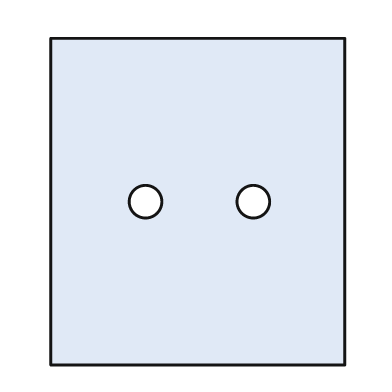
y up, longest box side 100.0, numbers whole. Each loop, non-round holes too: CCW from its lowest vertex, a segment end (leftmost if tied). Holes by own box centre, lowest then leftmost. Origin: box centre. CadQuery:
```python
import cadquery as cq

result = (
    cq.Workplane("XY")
    .moveTo(-45.0, -50.0)
    .lineTo(45.0, -50.0)
    .lineTo(45.0, 50.0)
    .lineTo(-45.0, 50.0)
    .close()
    .moveTo(-16.0, 0.0)
    .circle(5.0)
    .moveTo(17.0, 0.0)
    .circle(5.0)
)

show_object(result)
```